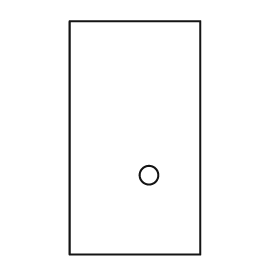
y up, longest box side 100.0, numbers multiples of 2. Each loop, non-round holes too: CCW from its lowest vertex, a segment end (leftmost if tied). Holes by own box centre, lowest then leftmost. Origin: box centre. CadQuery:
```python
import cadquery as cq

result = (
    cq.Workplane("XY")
    .moveTo(-28.0, -50.0)
    .lineTo(28.0, -50.0)
    .lineTo(28.0, 50.0)
    .lineTo(-28.0, 50.0)
    .close()
    .moveTo(6.0, -16.0)
    .circle(4.0)
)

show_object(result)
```